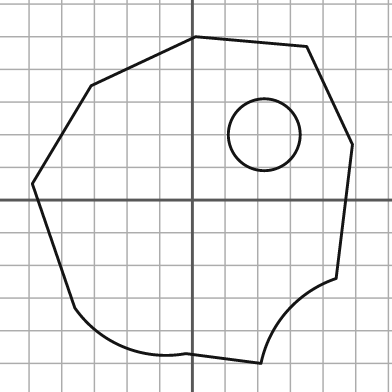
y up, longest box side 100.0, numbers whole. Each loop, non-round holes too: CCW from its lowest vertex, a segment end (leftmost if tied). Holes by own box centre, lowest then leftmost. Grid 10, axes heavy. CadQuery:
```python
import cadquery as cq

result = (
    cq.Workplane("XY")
    .moveTo(21.0, -50.0)
    .threePointArc((29.0, -34.0), (44.0, -24.0))
    .lineTo(49.0, 17.0)
    .lineTo(35.0, 47.0)
    .lineTo(1.0, 50.0)
    .lineTo(-31.0, 35.0)
    .lineTo(-49.0, 5.0)
    .lineTo(-36.0, -33.0)
    .threePointArc((-21.0, -45.0), (-2.0, -47.0))
    .close()
    .moveTo(22.0, 20.0)
    .circle(11.0)
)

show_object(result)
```